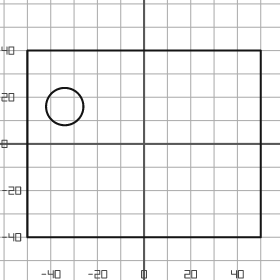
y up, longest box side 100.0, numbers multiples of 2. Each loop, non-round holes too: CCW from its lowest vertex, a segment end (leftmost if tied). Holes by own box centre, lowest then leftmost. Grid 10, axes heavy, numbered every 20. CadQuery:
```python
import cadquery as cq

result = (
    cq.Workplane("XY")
    .moveTo(-50.0, -40.0)
    .lineTo(50.0, -40.0)
    .lineTo(50.0, 40.0)
    .lineTo(-50.0, 40.0)
    .close()
    .moveTo(-34.0, 16.0)
    .circle(8.0)
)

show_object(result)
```